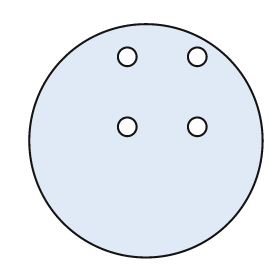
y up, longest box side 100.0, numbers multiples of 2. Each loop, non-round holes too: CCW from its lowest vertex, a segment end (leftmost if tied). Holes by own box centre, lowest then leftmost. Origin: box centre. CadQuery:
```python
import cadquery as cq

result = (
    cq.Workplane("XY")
    .moveTo(0.0, 0.0)
    .circle(50.0)
    .moveTo(-8.0, 6.0)
    .circle(4.0)
    .moveTo(22.0, 6.0)
    .circle(4.0)
    .moveTo(-8.0, 36.0)
    .circle(4.0)
    .moveTo(22.0, 36.0)
    .circle(4.0)
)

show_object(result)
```